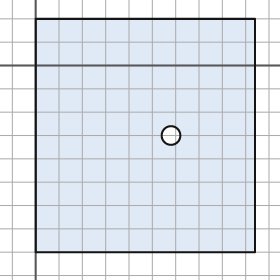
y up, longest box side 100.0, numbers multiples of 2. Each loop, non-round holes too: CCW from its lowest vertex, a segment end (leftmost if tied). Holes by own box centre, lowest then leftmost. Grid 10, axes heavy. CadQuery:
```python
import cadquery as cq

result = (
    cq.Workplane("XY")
    .moveTo(0.0, -80.0)
    .lineTo(94.0, -80.0)
    .lineTo(94.0, 20.0)
    .lineTo(0.0, 20.0)
    .close()
    .moveTo(58.0, -30.0)
    .circle(4.0)
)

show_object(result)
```